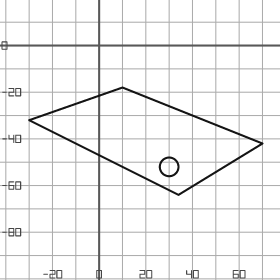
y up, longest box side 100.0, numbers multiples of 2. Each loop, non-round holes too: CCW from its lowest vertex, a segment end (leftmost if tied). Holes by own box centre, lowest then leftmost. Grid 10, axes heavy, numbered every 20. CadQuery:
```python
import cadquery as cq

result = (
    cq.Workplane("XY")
    .moveTo(34.0, -64.0)
    .lineTo(70.0, -42.0)
    .lineTo(10.0, -18.0)
    .lineTo(-30.0, -32.0)
    .close()
    .moveTo(30.0, -52.0)
    .circle(4.0)
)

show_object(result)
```